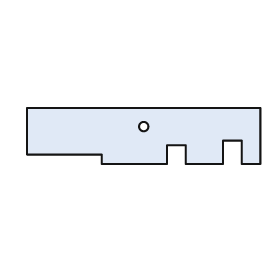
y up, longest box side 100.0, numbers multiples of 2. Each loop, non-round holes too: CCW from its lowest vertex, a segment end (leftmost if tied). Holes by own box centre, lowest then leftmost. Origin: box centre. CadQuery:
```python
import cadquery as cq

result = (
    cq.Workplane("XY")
    .moveTo(-18.0, -12.0)
    .lineTo(10.0, -12.0)
    .lineTo(10.0, -4.0)
    .lineTo(18.0, -4.0)
    .lineTo(18.0, -12.0)
    .lineTo(34.0, -12.0)
    .lineTo(34.0, -2.0)
    .lineTo(42.0, -2.0)
    .lineTo(42.0, -12.0)
    .lineTo(50.0, -12.0)
    .lineTo(50.0, 12.0)
    .lineTo(-50.0, 12.0)
    .lineTo(-50.0, -8.0)
    .lineTo(-18.0, -8.0)
    .close()
    .moveTo(0.0, 4.0)
    .circle(2.0)
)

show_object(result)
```